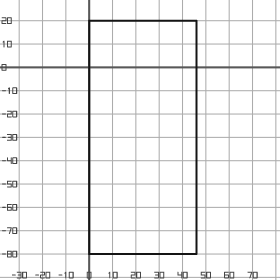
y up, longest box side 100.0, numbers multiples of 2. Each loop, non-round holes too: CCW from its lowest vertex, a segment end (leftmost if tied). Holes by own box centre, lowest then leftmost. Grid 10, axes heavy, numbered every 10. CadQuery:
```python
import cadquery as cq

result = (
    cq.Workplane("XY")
    .moveTo(0.0, -80.0)
    .lineTo(46.0, -80.0)
    .lineTo(46.0, 20.0)
    .lineTo(0.0, 20.0)
    .close()
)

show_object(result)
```